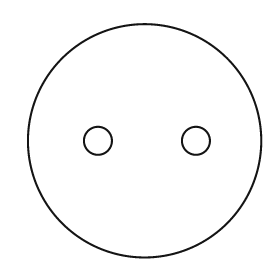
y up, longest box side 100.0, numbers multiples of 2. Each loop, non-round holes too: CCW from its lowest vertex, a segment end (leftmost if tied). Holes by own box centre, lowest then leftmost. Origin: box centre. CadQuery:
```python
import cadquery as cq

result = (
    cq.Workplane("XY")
    .moveTo(0.0, 0.0)
    .circle(50.0)
    .moveTo(-20.0, 0.0)
    .circle(6.0)
    .moveTo(22.0, 0.0)
    .circle(6.0)
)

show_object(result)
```